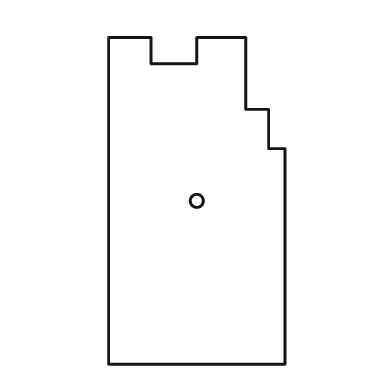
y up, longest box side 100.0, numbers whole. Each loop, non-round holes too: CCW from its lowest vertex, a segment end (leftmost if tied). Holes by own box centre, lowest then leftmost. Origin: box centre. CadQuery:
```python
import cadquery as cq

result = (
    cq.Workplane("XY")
    .moveTo(-27.0, -50.0)
    .lineTo(27.0, -50.0)
    .lineTo(27.0, 16.0)
    .lineTo(22.0, 16.0)
    .lineTo(22.0, 28.0)
    .lineTo(15.0, 28.0)
    .lineTo(15.0, 50.0)
    .lineTo(0.0, 50.0)
    .lineTo(0.0, 42.0)
    .lineTo(-14.0, 42.0)
    .lineTo(-14.0, 50.0)
    .lineTo(-27.0, 50.0)
    .close()
    .moveTo(0.0, 0.0)
    .circle(2.0)
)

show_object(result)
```